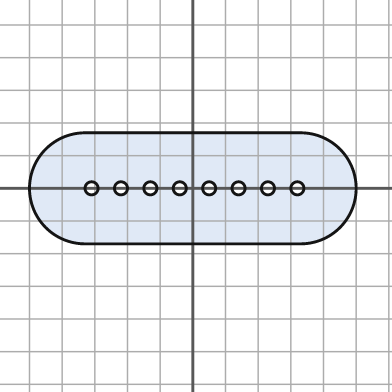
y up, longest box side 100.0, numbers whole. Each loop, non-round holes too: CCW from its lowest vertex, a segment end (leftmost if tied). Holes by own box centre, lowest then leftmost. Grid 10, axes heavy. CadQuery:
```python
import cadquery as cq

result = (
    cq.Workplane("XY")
    .moveTo(-33.0, -17.0)
    .lineTo(33.0, -17.0)
    .threePointArc((50.0, 0.0), (33.0, 17.0))
    .lineTo(-33.0, 17.0)
    .threePointArc((-50.0, 0.0), (-33.0, -17.0))
    .close()
    .moveTo(-31.0, 0.0)
    .circle(2.0)
    .moveTo(-22.0, 0.0)
    .circle(2.0)
    .moveTo(-13.0, 0.0)
    .circle(2.0)
    .moveTo(-4.0, 0.0)
    .circle(2.0)
    .moveTo(5.0, 0.0)
    .circle(2.0)
    .moveTo(14.0, 0.0)
    .circle(2.0)
    .moveTo(23.0, 0.0)
    .circle(2.0)
    .moveTo(32.0, 0.0)
    .circle(2.0)
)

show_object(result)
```